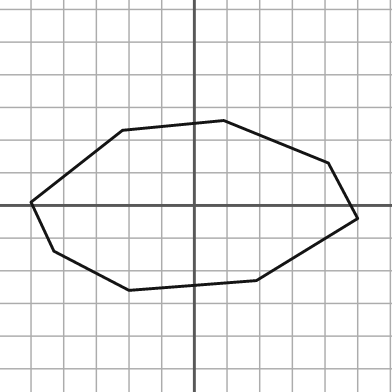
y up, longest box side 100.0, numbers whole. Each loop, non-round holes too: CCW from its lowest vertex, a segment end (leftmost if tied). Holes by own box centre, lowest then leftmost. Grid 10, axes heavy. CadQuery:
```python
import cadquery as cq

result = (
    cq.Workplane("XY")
    .moveTo(-20.0, -26.0)
    .lineTo(19.0, -23.0)
    .lineTo(50.0, -4.0)
    .lineTo(41.0, 13.0)
    .lineTo(9.0, 26.0)
    .lineTo(-22.0, 23.0)
    .lineTo(-50.0, 1.0)
    .lineTo(-43.0, -14.0)
    .close()
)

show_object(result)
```